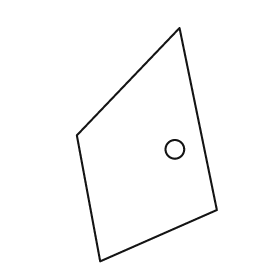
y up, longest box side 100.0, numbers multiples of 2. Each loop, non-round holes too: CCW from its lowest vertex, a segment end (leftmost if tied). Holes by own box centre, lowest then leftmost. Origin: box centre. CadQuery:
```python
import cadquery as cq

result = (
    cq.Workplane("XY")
    .moveTo(-20.0, -50.0)
    .lineTo(30.0, -28.0)
    .lineTo(14.0, 50.0)
    .lineTo(-30.0, 4.0)
    .close()
    .moveTo(12.0, -2.0)
    .circle(4.0)
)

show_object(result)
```